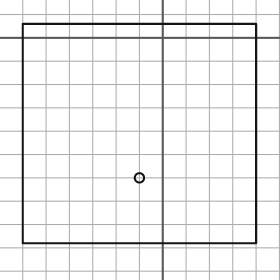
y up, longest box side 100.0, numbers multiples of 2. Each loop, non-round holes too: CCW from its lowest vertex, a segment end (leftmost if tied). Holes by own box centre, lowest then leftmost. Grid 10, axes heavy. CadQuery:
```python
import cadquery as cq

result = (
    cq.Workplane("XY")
    .moveTo(-60.0, -88.0)
    .lineTo(40.0, -88.0)
    .lineTo(40.0, 6.0)
    .lineTo(-60.0, 6.0)
    .close()
    .moveTo(-10.0, -60.0)
    .circle(2.0)
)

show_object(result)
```